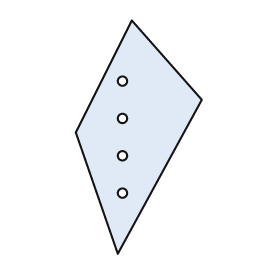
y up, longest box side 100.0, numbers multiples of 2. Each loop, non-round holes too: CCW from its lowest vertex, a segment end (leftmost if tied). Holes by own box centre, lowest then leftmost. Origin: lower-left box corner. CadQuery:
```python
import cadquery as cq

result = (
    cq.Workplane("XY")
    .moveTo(18.0, 0.0)
    .lineTo(54.0, 66.0)
    .lineTo(24.0, 100.0)
    .lineTo(0.0, 52.0)
    .close()
    .moveTo(20.0, 26.0)
    .circle(2.0)
    .moveTo(20.0, 42.0)
    .circle(2.0)
    .moveTo(20.0, 58.0)
    .circle(2.0)
    .moveTo(20.0, 74.0)
    .circle(2.0)
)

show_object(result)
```